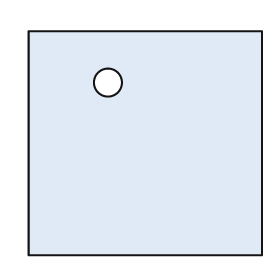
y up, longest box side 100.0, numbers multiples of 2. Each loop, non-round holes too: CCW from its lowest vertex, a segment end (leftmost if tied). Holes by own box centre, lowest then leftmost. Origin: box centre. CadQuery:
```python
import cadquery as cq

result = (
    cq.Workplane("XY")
    .moveTo(-50.0, -48.0)
    .lineTo(50.0, -48.0)
    .lineTo(50.0, 48.0)
    .lineTo(-50.0, 48.0)
    .close()
    .moveTo(-16.0, 26.0)
    .circle(6.0)
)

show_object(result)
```